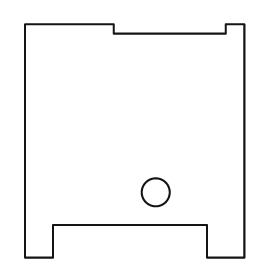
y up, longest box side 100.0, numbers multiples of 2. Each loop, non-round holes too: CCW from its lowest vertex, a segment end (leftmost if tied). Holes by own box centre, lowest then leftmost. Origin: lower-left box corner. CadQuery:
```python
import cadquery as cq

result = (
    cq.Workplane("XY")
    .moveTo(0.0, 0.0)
    .lineTo(12.0, 0.0)
    .lineTo(12.0, 14.0)
    .lineTo(78.0, 14.0)
    .lineTo(78.0, 0.0)
    .lineTo(94.0, 0.0)
    .lineTo(94.0, 100.0)
    .lineTo(86.0, 100.0)
    .lineTo(86.0, 96.0)
    .lineTo(38.0, 96.0)
    .lineTo(38.0, 100.0)
    .lineTo(0.0, 100.0)
    .close()
    .moveTo(56.0, 28.0)
    .circle(6.0)
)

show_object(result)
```